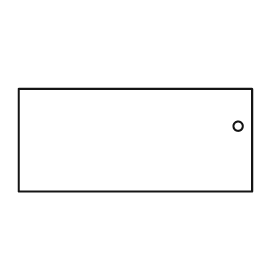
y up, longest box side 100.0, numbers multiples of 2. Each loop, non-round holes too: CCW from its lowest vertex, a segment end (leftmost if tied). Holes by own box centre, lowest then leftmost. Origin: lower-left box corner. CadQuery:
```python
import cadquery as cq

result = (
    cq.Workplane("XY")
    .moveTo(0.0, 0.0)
    .lineTo(100.0, 0.0)
    .lineTo(100.0, 44.0)
    .lineTo(0.0, 44.0)
    .close()
    .moveTo(94.0, 28.0)
    .circle(2.0)
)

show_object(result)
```